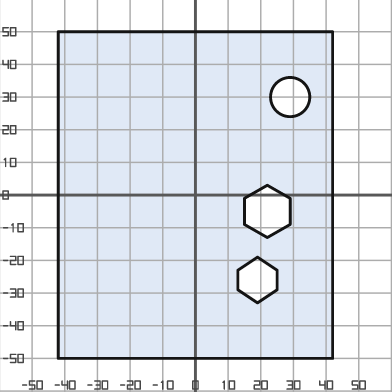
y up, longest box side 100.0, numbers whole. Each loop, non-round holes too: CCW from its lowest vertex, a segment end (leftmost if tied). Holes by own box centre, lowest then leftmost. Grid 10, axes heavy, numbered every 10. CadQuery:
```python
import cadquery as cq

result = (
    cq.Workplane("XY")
    .moveTo(-42.0, -50.0)
    .lineTo(42.0, -50.0)
    .lineTo(42.0, 50.0)
    .lineTo(-42.0, 50.0)
    .close()
    .moveTo(19.0, -33.0)
    .lineTo(25.0, -29.0)
    .lineTo(25.0, -23.0)
    .lineTo(19.0, -19.0)
    .lineTo(13.0, -23.0)
    .lineTo(13.0, -29.0)
    .close()
    .moveTo(22.0, -13.0)
    .lineTo(29.0, -9.0)
    .lineTo(29.0, -1.0)
    .lineTo(22.0, 3.0)
    .lineTo(15.0, -1.0)
    .lineTo(15.0, -9.0)
    .close()
    .moveTo(29.0, 30.0)
    .circle(6.0)
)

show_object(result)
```